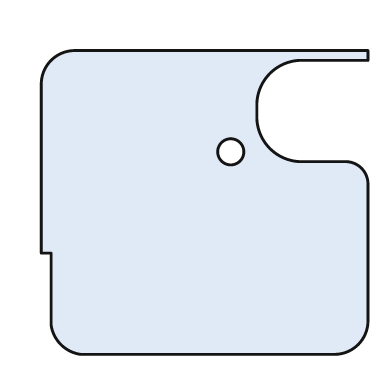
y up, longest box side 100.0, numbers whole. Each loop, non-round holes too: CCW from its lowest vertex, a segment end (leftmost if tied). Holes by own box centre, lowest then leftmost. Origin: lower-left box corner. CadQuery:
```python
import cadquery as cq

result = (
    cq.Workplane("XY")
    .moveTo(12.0, 0.0)
    .lineTo(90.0, 0.0)
    .threePointArc((97.0, 3.0), (100.0, 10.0))
    .lineTo(100.0, 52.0)
    .threePointArc((98.0, 57.0), (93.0, 59.0))
    .lineTo(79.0, 59.0)
    .threePointArc((70.0, 63.0), (66.0, 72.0))
    .lineTo(66.0, 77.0)
    .threePointArc((70.0, 86.0), (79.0, 90.0))
    .lineTo(100.0, 90.0)
    .lineTo(100.0, 93.0)
    .lineTo(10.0, 93.0)
    .threePointArc((3.0, 90.0), (0.0, 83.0))
    .lineTo(0.0, 31.0)
    .lineTo(3.0, 31.0)
    .lineTo(3.0, 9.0)
    .threePointArc((6.0, 3.0), (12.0, 0.0))
    .close()
    .moveTo(58.0, 62.0)
    .circle(4.0)
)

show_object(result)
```